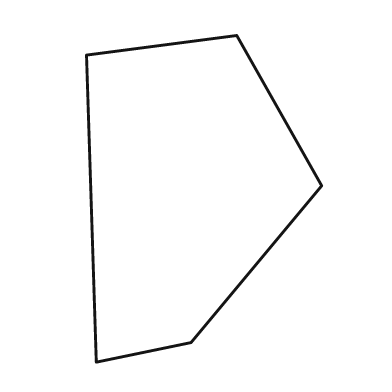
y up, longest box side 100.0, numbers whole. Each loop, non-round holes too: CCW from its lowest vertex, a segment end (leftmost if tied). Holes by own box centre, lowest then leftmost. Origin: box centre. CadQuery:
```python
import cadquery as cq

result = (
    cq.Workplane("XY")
    .moveTo(-33.0, -50.0)
    .lineTo(-4.0, -44.0)
    .lineTo(36.0, 4.0)
    .lineTo(10.0, 50.0)
    .lineTo(-36.0, 44.0)
    .close()
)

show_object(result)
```